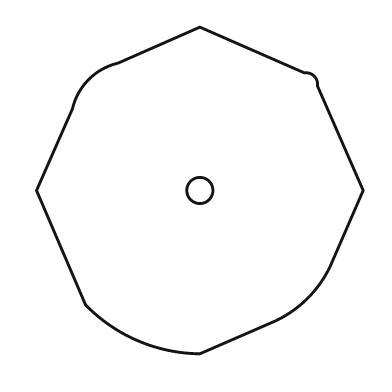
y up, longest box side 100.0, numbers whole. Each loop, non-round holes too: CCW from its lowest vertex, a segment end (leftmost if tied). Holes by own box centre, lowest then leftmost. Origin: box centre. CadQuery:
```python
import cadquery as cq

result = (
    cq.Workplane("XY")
    .moveTo(0.0, -50.0)
    .lineTo(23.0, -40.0)
    .threePointArc((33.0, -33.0), (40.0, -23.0))
    .lineTo(50.0, 0.0)
    .lineTo(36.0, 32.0)
    .threePointArc((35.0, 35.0), (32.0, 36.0))
    .lineTo(0.0, 50.0)
    .lineTo(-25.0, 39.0)
    .threePointArc((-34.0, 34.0), (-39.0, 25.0))
    .lineTo(-50.0, 0.0)
    .lineTo(-35.0, -35.0)
    .threePointArc((-19.0, -46.0), (0.0, -50.0))
    .close()
    .moveTo(0.0, 0.0)
    .circle(4.0)
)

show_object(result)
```